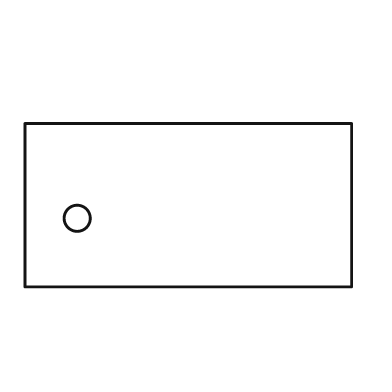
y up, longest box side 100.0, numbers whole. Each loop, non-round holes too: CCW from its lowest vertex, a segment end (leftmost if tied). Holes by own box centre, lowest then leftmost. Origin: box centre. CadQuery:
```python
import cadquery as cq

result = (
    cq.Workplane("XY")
    .moveTo(-50.0, -25.0)
    .lineTo(50.0, -25.0)
    .lineTo(50.0, 25.0)
    .lineTo(-50.0, 25.0)
    .close()
    .moveTo(-34.0, -4.0)
    .circle(4.0)
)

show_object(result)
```